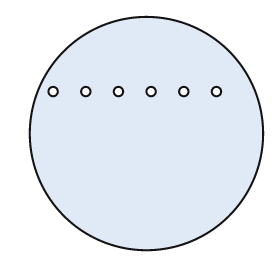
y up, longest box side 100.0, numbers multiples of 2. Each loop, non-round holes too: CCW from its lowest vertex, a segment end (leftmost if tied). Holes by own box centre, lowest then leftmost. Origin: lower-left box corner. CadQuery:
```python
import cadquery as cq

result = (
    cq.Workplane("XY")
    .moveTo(50.0, 50.0)
    .circle(50.0)
    .moveTo(10.0, 68.0)
    .circle(2.0)
    .moveTo(24.0, 68.0)
    .circle(2.0)
    .moveTo(38.0, 68.0)
    .circle(2.0)
    .moveTo(52.0, 68.0)
    .circle(2.0)
    .moveTo(66.0, 68.0)
    .circle(2.0)
    .moveTo(80.0, 68.0)
    .circle(2.0)
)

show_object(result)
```